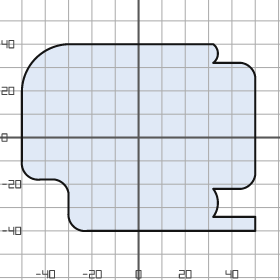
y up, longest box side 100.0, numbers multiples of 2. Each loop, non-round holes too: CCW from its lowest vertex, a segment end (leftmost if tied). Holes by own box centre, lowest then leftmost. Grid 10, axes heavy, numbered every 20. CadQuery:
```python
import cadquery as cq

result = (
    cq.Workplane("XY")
    .moveTo(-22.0, -40.0)
    .lineTo(50.0, -40.0)
    .lineTo(50.0, -34.0)
    .lineTo(32.0, -34.0)
    .threePointArc((34.0, -28.0), (32.0, -22.0))
    .lineTo(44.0, -22.0)
    .threePointArc((48.0, -20.0), (50.0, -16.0))
    .lineTo(50.0, 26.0)
    .threePointArc((48.0, 30.0), (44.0, 32.0))
    .lineTo(32.0, 32.0)
    .threePointArc((34.0, 36.0), (32.0, 40.0))
    .lineTo(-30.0, 40.0)
    .threePointArc((-44.0, 34.0), (-50.0, 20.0))
    .lineTo(-50.0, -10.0)
    .threePointArc((-48.0, -16.0), (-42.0, -18.0))
    .lineTo(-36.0, -18.0)
    .threePointArc((-32.0, -20.0), (-30.0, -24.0))
    .lineTo(-30.0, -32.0)
    .threePointArc((-28.0, -38.0), (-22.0, -40.0))
    .close()
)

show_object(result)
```